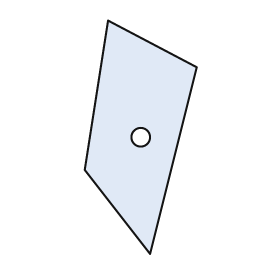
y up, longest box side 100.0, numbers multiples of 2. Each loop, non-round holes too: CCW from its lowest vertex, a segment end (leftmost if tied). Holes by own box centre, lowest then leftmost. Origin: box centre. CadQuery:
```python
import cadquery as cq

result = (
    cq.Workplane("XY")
    .moveTo(4.0, -50.0)
    .lineTo(24.0, 30.0)
    .lineTo(-14.0, 50.0)
    .lineTo(-24.0, -14.0)
    .close()
    .moveTo(0.0, 0.0)
    .circle(4.0)
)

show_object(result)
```